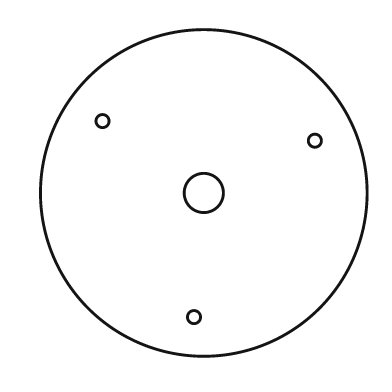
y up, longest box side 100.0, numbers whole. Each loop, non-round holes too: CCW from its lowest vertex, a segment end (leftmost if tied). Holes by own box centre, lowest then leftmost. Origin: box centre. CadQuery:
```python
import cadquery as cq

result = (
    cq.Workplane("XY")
    .moveTo(0.0, 0.0)
    .circle(50.0)
    .moveTo(-3.0, -38.0)
    .circle(2.0)
    .moveTo(0.0, 0.0)
    .circle(6.0)
    .moveTo(34.0, 16.0)
    .circle(2.0)
    .moveTo(-31.0, 22.0)
    .circle(2.0)
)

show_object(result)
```